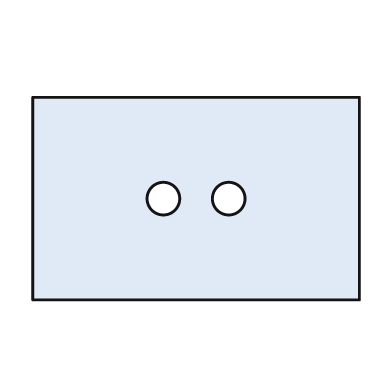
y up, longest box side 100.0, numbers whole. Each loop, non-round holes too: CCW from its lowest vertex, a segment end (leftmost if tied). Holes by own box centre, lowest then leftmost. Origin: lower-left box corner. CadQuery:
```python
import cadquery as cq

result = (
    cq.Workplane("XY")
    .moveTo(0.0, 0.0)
    .lineTo(100.0, 0.0)
    .lineTo(100.0, 62.0)
    .lineTo(0.0, 62.0)
    .close()
    .moveTo(40.0, 31.0)
    .circle(5.0)
    .moveTo(60.0, 31.0)
    .circle(5.0)
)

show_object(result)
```